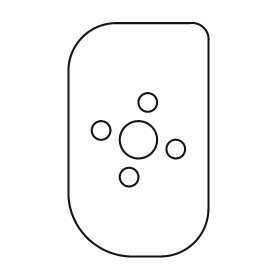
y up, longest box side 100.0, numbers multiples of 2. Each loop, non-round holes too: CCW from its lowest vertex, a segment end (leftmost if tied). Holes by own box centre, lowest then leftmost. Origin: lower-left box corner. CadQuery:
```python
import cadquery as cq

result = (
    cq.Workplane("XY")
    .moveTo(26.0, 0.0)
    .lineTo(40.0, 0.0)
    .threePointArc((54.0, 6.0), (60.0, 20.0))
    .lineTo(60.0, 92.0)
    .threePointArc((58.0, 98.0), (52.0, 100.0))
    .lineTo(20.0, 100.0)
    .threePointArc((6.0, 94.0), (0.0, 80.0))
    .lineTo(0.0, 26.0)
    .threePointArc((8.0, 8.0), (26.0, 0.0))
    .close()
    .moveTo(26.0, 34.0)
    .circle(4.0)
    .moveTo(46.0, 46.0)
    .circle(4.0)
    .moveTo(30.0, 50.0)
    .circle(8.0)
    .moveTo(14.0, 54.0)
    .circle(4.0)
    .moveTo(34.0, 66.0)
    .circle(4.0)
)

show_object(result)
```